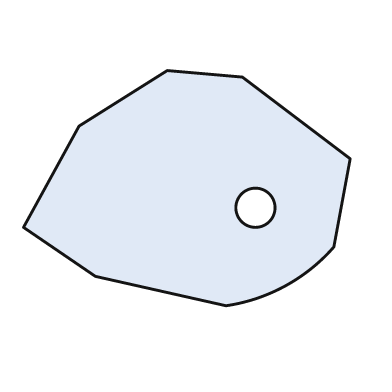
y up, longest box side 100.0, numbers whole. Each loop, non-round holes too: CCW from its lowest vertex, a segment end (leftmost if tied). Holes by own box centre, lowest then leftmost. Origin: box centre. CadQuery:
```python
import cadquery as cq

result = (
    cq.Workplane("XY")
    .moveTo(12.0, -36.0)
    .threePointArc((30.0, -30.0), (45.0, -18.0))
    .lineTo(50.0, 9.0)
    .lineTo(17.0, 34.0)
    .lineTo(-6.0, 36.0)
    .lineTo(-33.0, 19.0)
    .lineTo(-50.0, -12.0)
    .lineTo(-28.0, -27.0)
    .close()
    .moveTo(21.0, -6.0)
    .circle(6.0)
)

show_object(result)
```